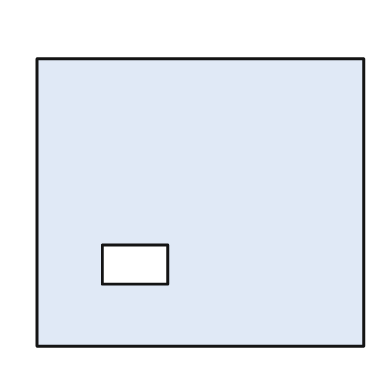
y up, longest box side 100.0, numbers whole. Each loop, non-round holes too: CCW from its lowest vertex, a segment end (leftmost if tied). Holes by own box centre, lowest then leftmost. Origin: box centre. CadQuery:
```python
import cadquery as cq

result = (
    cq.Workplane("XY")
    .moveTo(-50.0, -44.0)
    .lineTo(50.0, -44.0)
    .lineTo(50.0, 44.0)
    .lineTo(-50.0, 44.0)
    .close()
    .moveTo(-30.0, -25.0)
    .lineTo(-10.0, -25.0)
    .lineTo(-10.0, -13.0)
    .lineTo(-30.0, -13.0)
    .close()
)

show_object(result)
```